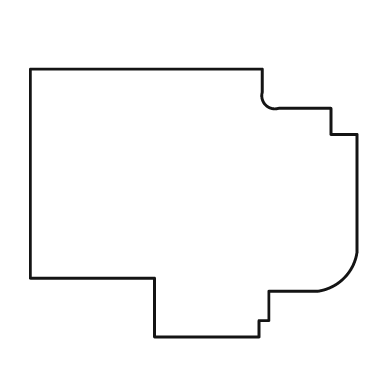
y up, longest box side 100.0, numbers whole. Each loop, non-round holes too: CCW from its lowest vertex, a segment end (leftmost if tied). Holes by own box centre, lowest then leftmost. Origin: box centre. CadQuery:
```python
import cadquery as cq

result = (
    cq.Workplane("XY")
    .moveTo(-12.0, -41.0)
    .lineTo(20.0, -41.0)
    .lineTo(20.0, -36.0)
    .lineTo(23.0, -36.0)
    .lineTo(23.0, -27.0)
    .lineTo(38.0, -27.0)
    .threePointArc((46.0, -23.0), (50.0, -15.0))
    .lineTo(50.0, 21.0)
    .lineTo(42.0, 21.0)
    .lineTo(42.0, 29.0)
    .lineTo(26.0, 29.0)
    .threePointArc((22.0, 30.0), (21.0, 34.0))
    .lineTo(21.0, 41.0)
    .lineTo(-50.0, 41.0)
    .lineTo(-50.0, -23.0)
    .lineTo(-12.0, -23.0)
    .close()
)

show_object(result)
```